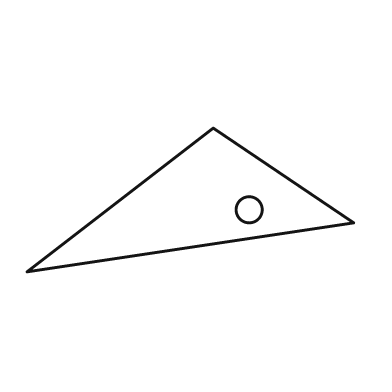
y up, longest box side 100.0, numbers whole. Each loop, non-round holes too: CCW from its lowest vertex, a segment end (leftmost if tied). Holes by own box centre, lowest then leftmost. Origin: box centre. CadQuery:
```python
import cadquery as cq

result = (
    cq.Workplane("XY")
    .moveTo(-50.0, -22.0)
    .lineTo(50.0, -7.0)
    .lineTo(7.0, 22.0)
    .close()
    .moveTo(18.0, -3.0)
    .circle(4.0)
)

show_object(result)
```